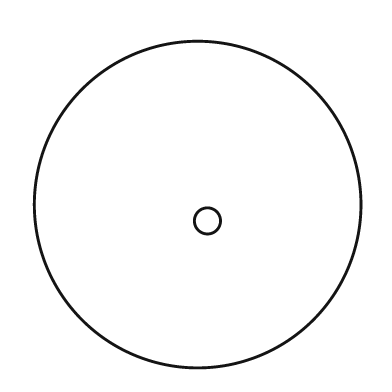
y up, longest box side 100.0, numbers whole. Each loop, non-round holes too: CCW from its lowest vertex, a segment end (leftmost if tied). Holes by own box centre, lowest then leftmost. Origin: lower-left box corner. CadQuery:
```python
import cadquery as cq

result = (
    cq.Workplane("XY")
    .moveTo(50.0, 50.0)
    .circle(50.0)
    .moveTo(53.0, 45.0)
    .circle(4.0)
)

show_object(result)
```